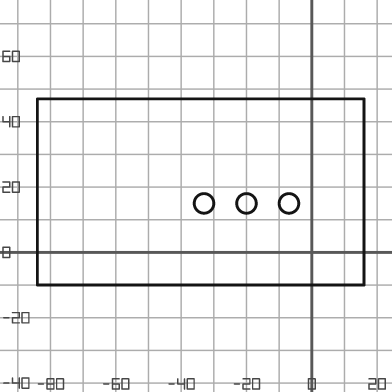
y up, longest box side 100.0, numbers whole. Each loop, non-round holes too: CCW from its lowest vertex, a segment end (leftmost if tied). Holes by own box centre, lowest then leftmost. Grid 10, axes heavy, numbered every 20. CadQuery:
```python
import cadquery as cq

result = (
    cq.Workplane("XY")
    .moveTo(-84.0, -10.0)
    .lineTo(16.0, -10.0)
    .lineTo(16.0, 47.0)
    .lineTo(-84.0, 47.0)
    .close()
    .moveTo(-33.0, 15.0)
    .circle(3.0)
    .moveTo(-20.0, 15.0)
    .circle(3.0)
    .moveTo(-7.0, 15.0)
    .circle(3.0)
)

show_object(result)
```